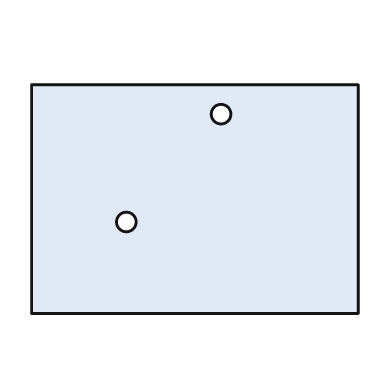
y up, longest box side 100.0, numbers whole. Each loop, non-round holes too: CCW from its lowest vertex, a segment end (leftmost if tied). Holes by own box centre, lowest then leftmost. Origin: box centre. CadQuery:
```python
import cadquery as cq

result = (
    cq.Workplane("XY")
    .moveTo(-50.0, -35.0)
    .lineTo(50.0, -35.0)
    .lineTo(50.0, 35.0)
    .lineTo(-50.0, 35.0)
    .close()
    .moveTo(-21.0, -7.0)
    .circle(3.0)
    .moveTo(8.0, 26.0)
    .circle(3.0)
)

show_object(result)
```